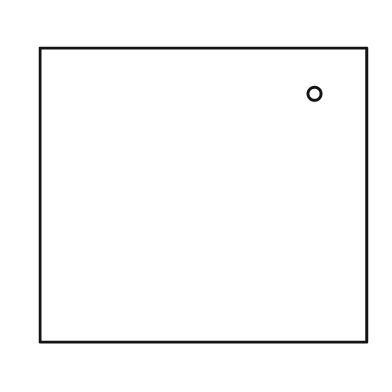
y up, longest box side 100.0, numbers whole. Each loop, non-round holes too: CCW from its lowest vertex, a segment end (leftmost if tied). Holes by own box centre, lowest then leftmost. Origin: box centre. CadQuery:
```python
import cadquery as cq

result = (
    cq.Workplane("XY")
    .moveTo(-50.0, -45.0)
    .lineTo(50.0, -45.0)
    .lineTo(50.0, 45.0)
    .lineTo(-50.0, 45.0)
    .close()
    .moveTo(34.0, 31.0)
    .circle(2.0)
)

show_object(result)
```